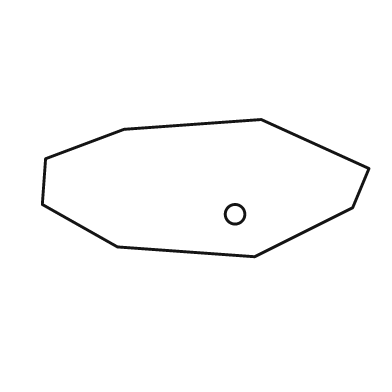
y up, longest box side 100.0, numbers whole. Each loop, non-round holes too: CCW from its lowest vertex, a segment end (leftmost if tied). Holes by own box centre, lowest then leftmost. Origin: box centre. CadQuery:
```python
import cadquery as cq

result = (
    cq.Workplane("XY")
    .moveTo(15.0, -21.0)
    .lineTo(45.0, -6.0)
    .lineTo(50.0, 6.0)
    .lineTo(17.0, 21.0)
    .lineTo(-25.0, 18.0)
    .lineTo(-49.0, 9.0)
    .lineTo(-50.0, -5.0)
    .lineTo(-27.0, -18.0)
    .close()
    .moveTo(9.0, -8.0)
    .circle(3.0)
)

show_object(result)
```